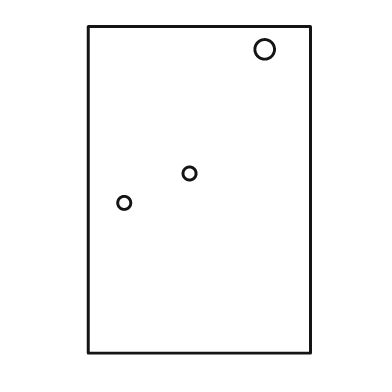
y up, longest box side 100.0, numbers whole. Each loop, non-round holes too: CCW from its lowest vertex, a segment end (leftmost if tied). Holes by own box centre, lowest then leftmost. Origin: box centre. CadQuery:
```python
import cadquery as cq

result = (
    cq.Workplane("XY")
    .moveTo(-34.0, -50.0)
    .lineTo(34.0, -50.0)
    .lineTo(34.0, 50.0)
    .lineTo(-34.0, 50.0)
    .close()
    .moveTo(-23.0, -4.0)
    .circle(2.0)
    .moveTo(-3.0, 5.0)
    .circle(2.0)
    .moveTo(20.0, 43.0)
    .circle(3.0)
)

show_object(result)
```